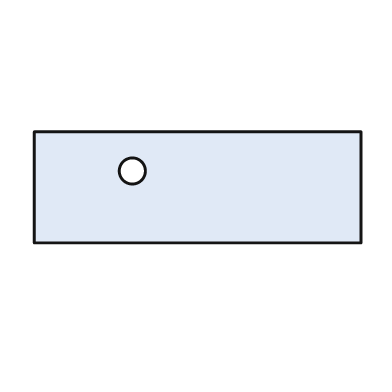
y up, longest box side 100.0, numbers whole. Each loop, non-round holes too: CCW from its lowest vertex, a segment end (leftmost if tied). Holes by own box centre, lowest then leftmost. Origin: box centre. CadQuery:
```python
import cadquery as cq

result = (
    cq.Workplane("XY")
    .moveTo(-50.0, -17.0)
    .lineTo(50.0, -17.0)
    .lineTo(50.0, 17.0)
    .lineTo(-50.0, 17.0)
    .close()
    .moveTo(-20.0, 5.0)
    .circle(4.0)
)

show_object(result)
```